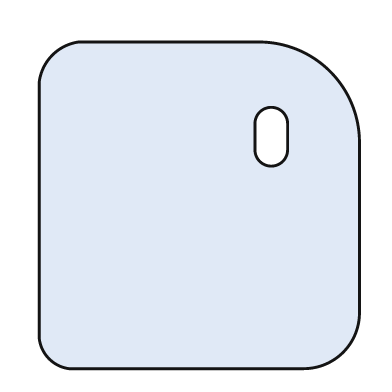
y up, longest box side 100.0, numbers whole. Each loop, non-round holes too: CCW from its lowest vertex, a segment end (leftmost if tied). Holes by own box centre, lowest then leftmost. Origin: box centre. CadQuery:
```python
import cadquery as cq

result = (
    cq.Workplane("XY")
    .moveTo(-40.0, -50.0)
    .lineTo(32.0, -50.0)
    .threePointArc((44.0, -45.0), (49.0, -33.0))
    .lineTo(49.0, 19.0)
    .threePointArc((40.0, 41.0), (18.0, 50.0))
    .lineTo(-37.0, 50.0)
    .threePointArc((-45.0, 46.0), (-49.0, 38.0))
    .lineTo(-49.0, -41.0)
    .threePointArc((-46.0, -47.0), (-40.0, -50.0))
    .close()
    .moveTo(17.0, 17.0)
    .threePointArc((22.0, 12.0), (27.0, 17.0))
    .lineTo(27.0, 25.0)
    .threePointArc((22.0, 30.0), (17.0, 25.0))
    .close()
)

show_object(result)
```